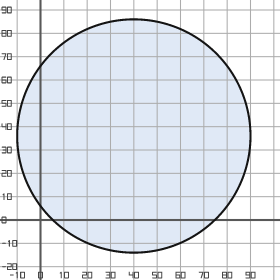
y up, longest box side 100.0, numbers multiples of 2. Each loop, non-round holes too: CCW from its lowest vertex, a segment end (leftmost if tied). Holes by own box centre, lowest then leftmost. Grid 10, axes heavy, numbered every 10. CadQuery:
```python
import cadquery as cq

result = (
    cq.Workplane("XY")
    .moveTo(40.0, 36.0)
    .circle(50.0)
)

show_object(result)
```